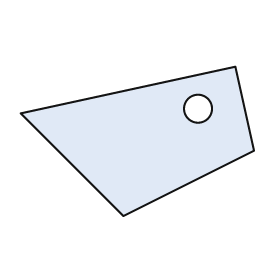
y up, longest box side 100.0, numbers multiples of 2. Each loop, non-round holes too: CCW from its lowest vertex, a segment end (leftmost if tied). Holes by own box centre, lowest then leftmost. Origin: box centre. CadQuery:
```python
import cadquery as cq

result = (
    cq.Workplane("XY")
    .moveTo(-6.0, -32.0)
    .lineTo(50.0, -4.0)
    .lineTo(42.0, 32.0)
    .lineTo(-50.0, 12.0)
    .close()
    .moveTo(26.0, 14.0)
    .circle(6.0)
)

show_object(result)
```